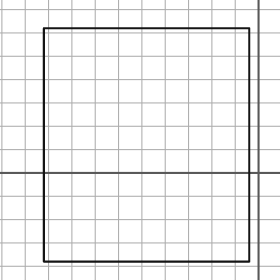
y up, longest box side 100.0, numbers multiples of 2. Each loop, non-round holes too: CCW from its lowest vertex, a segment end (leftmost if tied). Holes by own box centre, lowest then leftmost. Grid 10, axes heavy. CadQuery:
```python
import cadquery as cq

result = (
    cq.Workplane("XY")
    .moveTo(-92.0, -38.0)
    .lineTo(-4.0, -38.0)
    .lineTo(-4.0, 62.0)
    .lineTo(-92.0, 62.0)
    .close()
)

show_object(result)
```